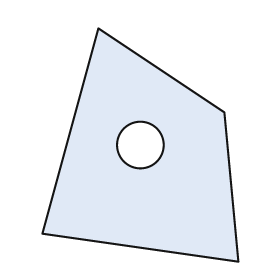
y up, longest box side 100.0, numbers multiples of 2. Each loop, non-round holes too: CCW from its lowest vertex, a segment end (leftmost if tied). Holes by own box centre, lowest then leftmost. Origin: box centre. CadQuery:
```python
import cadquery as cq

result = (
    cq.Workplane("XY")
    .moveTo(42.0, -50.0)
    .lineTo(36.0, 14.0)
    .lineTo(-18.0, 50.0)
    .lineTo(-42.0, -38.0)
    .close()
    .moveTo(0.0, 0.0)
    .circle(10.0)
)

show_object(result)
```